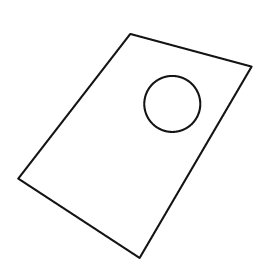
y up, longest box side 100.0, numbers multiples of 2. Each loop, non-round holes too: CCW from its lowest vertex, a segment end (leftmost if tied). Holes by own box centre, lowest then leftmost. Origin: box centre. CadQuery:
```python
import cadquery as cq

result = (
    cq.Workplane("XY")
    .moveTo(2.0, -48.0)
    .lineTo(50.0, 34.0)
    .lineTo(-2.0, 48.0)
    .lineTo(-50.0, -14.0)
    .close()
    .moveTo(16.0, 18.0)
    .circle(12.0)
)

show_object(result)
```